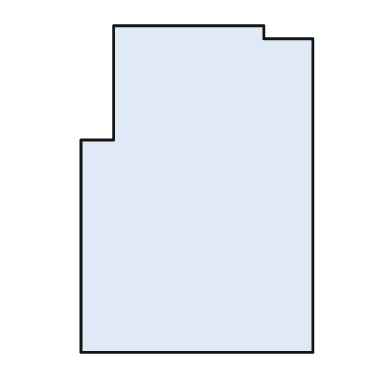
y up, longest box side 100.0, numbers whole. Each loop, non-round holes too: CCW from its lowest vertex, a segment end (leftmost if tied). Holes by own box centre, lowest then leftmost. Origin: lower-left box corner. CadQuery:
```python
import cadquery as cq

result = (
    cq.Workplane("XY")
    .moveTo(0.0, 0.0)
    .lineTo(71.0, 0.0)
    .lineTo(71.0, 96.0)
    .lineTo(56.0, 96.0)
    .lineTo(56.0, 100.0)
    .lineTo(10.0, 100.0)
    .lineTo(10.0, 65.0)
    .lineTo(0.0, 65.0)
    .close()
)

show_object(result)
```